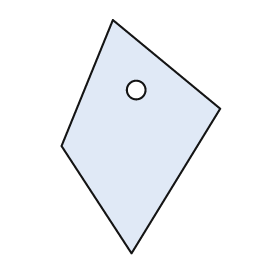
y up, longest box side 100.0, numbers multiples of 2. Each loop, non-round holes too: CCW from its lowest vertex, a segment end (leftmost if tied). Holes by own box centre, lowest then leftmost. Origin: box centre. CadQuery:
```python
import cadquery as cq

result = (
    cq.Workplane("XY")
    .moveTo(-4.0, -50.0)
    .lineTo(34.0, 12.0)
    .lineTo(-12.0, 50.0)
    .lineTo(-34.0, -4.0)
    .close()
    .moveTo(-2.0, 20.0)
    .circle(4.0)
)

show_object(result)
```